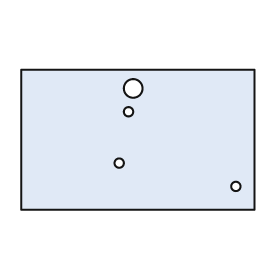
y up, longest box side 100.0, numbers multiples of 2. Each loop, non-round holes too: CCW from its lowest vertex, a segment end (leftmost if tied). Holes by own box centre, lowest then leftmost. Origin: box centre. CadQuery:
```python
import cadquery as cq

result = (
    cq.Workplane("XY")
    .moveTo(-50.0, -30.0)
    .lineTo(50.0, -30.0)
    .lineTo(50.0, 30.0)
    .lineTo(-50.0, 30.0)
    .close()
    .moveTo(42.0, -20.0)
    .circle(2.0)
    .moveTo(-8.0, -10.0)
    .circle(2.0)
    .moveTo(-4.0, 12.0)
    .circle(2.0)
    .moveTo(-2.0, 22.0)
    .circle(4.0)
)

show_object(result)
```